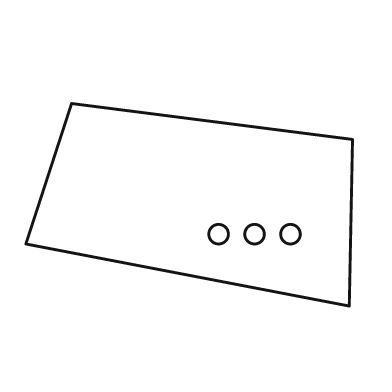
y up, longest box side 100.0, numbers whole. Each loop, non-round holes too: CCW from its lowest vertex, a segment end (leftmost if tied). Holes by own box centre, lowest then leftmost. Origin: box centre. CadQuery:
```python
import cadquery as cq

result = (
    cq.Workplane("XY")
    .moveTo(49.0, -31.0)
    .lineTo(50.0, 20.0)
    .lineTo(-36.0, 31.0)
    .lineTo(-50.0, -12.0)
    .close()
    .moveTo(9.0, -9.0)
    .circle(3.0)
    .moveTo(20.0, -9.0)
    .circle(3.0)
    .moveTo(31.0, -9.0)
    .circle(3.0)
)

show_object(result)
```